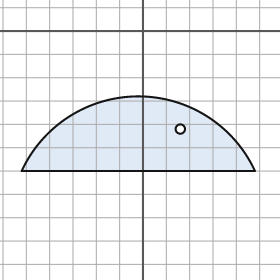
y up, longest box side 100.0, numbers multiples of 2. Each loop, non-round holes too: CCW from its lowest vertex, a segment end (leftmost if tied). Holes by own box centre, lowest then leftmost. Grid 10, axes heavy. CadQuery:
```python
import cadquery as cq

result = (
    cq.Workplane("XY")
    .moveTo(-52.0, -60.0)
    .lineTo(48.0, -60.0)
    .threePointArc((-2.0, -28.0), (-52.0, -60.0))
    .close()
    .moveTo(16.0, -42.0)
    .circle(2.0)
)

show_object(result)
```